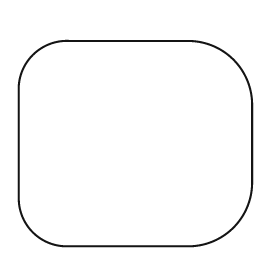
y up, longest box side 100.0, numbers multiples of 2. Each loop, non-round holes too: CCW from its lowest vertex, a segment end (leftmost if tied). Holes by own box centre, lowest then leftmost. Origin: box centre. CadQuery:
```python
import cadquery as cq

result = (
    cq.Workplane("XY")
    .moveTo(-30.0, -44.0)
    .lineTo(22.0, -44.0)
    .threePointArc((42.0, -36.0), (50.0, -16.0))
    .lineTo(50.0, 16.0)
    .threePointArc((42.0, 36.0), (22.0, 44.0))
    .lineTo(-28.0, 44.0)
    .threePointArc((-44.0, 38.0), (-50.0, 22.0))
    .lineTo(-50.0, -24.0)
    .threePointArc((-44.0, -38.0), (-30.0, -44.0))
    .close()
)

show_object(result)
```